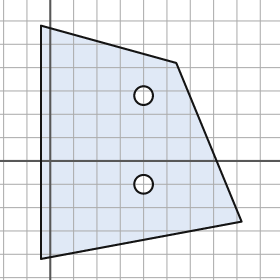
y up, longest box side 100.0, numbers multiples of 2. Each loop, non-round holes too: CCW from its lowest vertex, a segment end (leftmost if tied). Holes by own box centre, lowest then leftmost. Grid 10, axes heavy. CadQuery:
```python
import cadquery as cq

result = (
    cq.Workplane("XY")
    .moveTo(-4.0, -42.0)
    .lineTo(82.0, -26.0)
    .lineTo(54.0, 42.0)
    .lineTo(-4.0, 58.0)
    .close()
    .moveTo(40.0, -10.0)
    .circle(4.0)
    .moveTo(40.0, 28.0)
    .circle(4.0)
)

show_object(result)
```